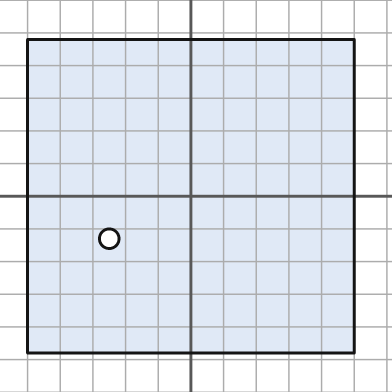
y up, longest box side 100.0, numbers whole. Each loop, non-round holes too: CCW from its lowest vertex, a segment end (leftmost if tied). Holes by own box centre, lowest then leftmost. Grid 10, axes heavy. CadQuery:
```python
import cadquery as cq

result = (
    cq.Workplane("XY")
    .moveTo(-50.0, -48.0)
    .lineTo(50.0, -48.0)
    .lineTo(50.0, 48.0)
    .lineTo(-50.0, 48.0)
    .close()
    .moveTo(-25.0, -13.0)
    .circle(3.0)
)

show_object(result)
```